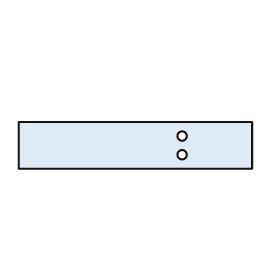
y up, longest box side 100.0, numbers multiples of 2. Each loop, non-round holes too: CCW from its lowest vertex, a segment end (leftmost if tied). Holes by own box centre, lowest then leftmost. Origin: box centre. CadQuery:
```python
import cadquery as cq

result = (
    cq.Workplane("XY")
    .moveTo(-50.0, -10.0)
    .lineTo(50.0, -10.0)
    .lineTo(50.0, 10.0)
    .lineTo(-50.0, 10.0)
    .close()
    .moveTo(20.0, -4.0)
    .circle(2.0)
    .moveTo(20.0, 4.0)
    .circle(2.0)
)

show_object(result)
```